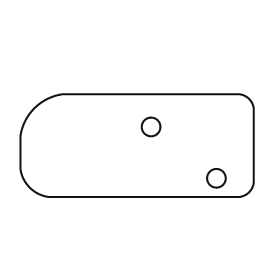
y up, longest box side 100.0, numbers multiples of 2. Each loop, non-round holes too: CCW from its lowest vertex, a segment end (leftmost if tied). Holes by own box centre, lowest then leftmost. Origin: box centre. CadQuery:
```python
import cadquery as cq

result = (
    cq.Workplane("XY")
    .moveTo(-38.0, -22.0)
    .lineTo(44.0, -22.0)
    .threePointArc((48.0, -20.0), (50.0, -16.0))
    .lineTo(50.0, 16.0)
    .threePointArc((48.0, 20.0), (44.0, 22.0))
    .lineTo(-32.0, 22.0)
    .threePointArc((-44.0, 16.0), (-50.0, 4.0))
    .lineTo(-50.0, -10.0)
    .threePointArc((-46.0, -18.0), (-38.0, -22.0))
    .close()
    .moveTo(34.0, -14.0)
    .circle(4.0)
    .moveTo(6.0, 8.0)
    .circle(4.0)
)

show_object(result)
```